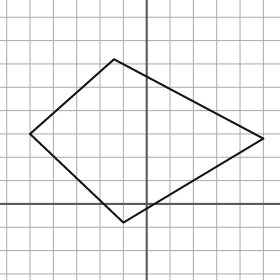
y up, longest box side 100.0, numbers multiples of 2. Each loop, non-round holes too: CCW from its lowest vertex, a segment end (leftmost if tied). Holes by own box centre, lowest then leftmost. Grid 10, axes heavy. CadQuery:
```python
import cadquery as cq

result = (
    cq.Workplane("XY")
    .moveTo(-10.0, -8.0)
    .lineTo(50.0, 28.0)
    .lineTo(-14.0, 62.0)
    .lineTo(-50.0, 30.0)
    .close()
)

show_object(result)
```